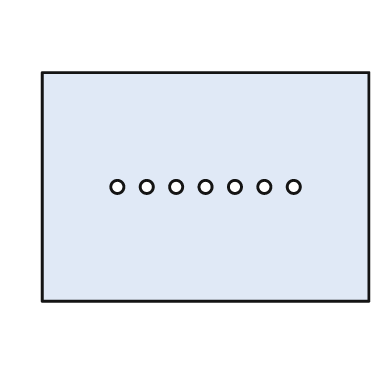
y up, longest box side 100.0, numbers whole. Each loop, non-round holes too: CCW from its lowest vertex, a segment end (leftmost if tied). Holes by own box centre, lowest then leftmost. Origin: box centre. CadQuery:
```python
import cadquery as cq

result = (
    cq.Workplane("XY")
    .moveTo(-50.0, -35.0)
    .lineTo(50.0, -35.0)
    .lineTo(50.0, 35.0)
    .lineTo(-50.0, 35.0)
    .close()
    .moveTo(-27.0, 0.0)
    .circle(2.0)
    .moveTo(-18.0, 0.0)
    .circle(2.0)
    .moveTo(-9.0, 0.0)
    .circle(2.0)
    .moveTo(0.0, 0.0)
    .circle(2.0)
    .moveTo(9.0, 0.0)
    .circle(2.0)
    .moveTo(18.0, 0.0)
    .circle(2.0)
    .moveTo(27.0, 0.0)
    .circle(2.0)
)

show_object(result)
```